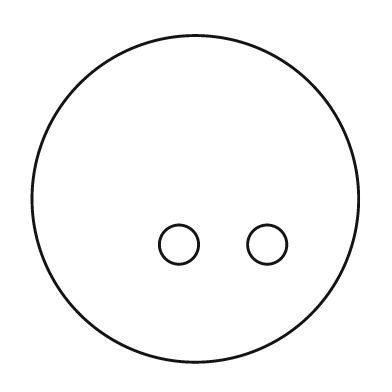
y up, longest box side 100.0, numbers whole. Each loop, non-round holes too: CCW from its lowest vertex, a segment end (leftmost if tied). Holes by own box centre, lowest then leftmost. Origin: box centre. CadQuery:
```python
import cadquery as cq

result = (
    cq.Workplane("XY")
    .moveTo(0.0, 0.0)
    .circle(50.0)
    .moveTo(-5.0, -14.0)
    .circle(6.0)
    .moveTo(22.0, -14.0)
    .circle(6.0)
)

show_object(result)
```